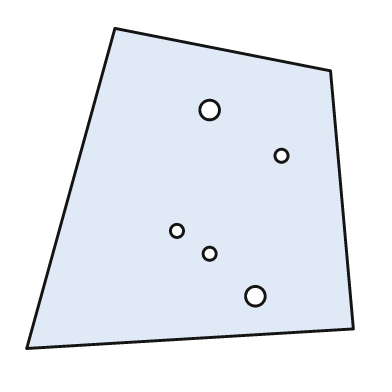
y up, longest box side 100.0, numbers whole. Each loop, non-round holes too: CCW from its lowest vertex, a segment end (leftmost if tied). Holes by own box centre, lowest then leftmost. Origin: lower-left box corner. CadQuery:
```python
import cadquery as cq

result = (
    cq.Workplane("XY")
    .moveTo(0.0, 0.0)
    .lineTo(100.0, 6.0)
    .lineTo(93.0, 85.0)
    .lineTo(27.0, 98.0)
    .close()
    .moveTo(70.0, 16.0)
    .circle(3.0)
    .moveTo(56.0, 29.0)
    .circle(2.0)
    .moveTo(46.0, 36.0)
    .circle(2.0)
    .moveTo(78.0, 59.0)
    .circle(2.0)
    .moveTo(56.0, 73.0)
    .circle(3.0)
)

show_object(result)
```